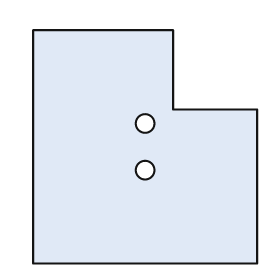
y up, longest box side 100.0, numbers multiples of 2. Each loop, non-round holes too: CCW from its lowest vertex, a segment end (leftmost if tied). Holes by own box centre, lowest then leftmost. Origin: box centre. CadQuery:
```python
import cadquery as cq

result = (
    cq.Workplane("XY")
    .moveTo(-48.0, -50.0)
    .lineTo(48.0, -50.0)
    .lineTo(48.0, 16.0)
    .lineTo(12.0, 16.0)
    .lineTo(12.0, 50.0)
    .lineTo(-48.0, 50.0)
    .close()
    .moveTo(0.0, -10.0)
    .circle(4.0)
    .moveTo(0.0, 10.0)
    .circle(4.0)
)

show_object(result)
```